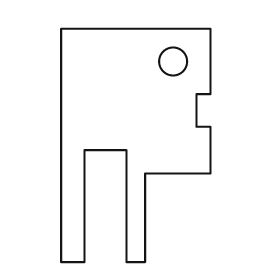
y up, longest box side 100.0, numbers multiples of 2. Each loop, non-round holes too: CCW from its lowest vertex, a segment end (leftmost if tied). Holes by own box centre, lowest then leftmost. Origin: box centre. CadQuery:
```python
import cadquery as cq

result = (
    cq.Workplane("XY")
    .moveTo(-32.0, -50.0)
    .lineTo(-22.0, -50.0)
    .lineTo(-22.0, -2.0)
    .lineTo(-4.0, -2.0)
    .lineTo(-4.0, -50.0)
    .lineTo(4.0, -50.0)
    .lineTo(4.0, -12.0)
    .lineTo(32.0, -12.0)
    .lineTo(32.0, 8.0)
    .lineTo(26.0, 8.0)
    .lineTo(26.0, 22.0)
    .lineTo(32.0, 22.0)
    .lineTo(32.0, 50.0)
    .lineTo(-32.0, 50.0)
    .close()
    .moveTo(16.0, 36.0)
    .circle(6.0)
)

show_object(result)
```